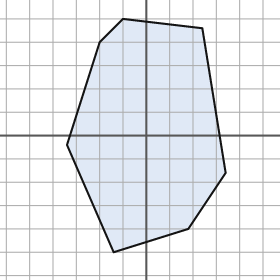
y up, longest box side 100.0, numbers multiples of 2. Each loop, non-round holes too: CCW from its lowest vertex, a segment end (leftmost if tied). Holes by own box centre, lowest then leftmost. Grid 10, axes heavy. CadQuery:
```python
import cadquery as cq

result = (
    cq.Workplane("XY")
    .moveTo(-14.0, -50.0)
    .lineTo(18.0, -40.0)
    .lineTo(34.0, -16.0)
    .lineTo(24.0, 46.0)
    .lineTo(-10.0, 50.0)
    .lineTo(-20.0, 40.0)
    .lineTo(-34.0, -4.0)
    .close()
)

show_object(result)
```